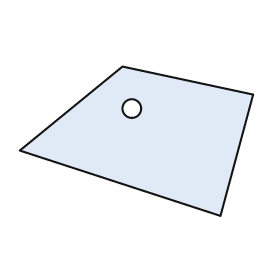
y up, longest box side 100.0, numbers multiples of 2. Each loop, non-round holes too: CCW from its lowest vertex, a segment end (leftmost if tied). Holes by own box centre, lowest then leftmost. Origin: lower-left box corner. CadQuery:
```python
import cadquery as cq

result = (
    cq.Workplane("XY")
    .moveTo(86.0, 0.0)
    .lineTo(100.0, 52.0)
    .lineTo(44.0, 64.0)
    .lineTo(0.0, 28.0)
    .close()
    .moveTo(48.0, 46.0)
    .circle(4.0)
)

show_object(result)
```